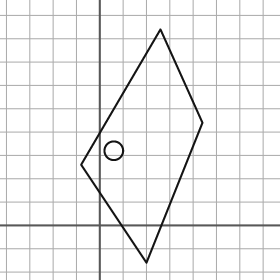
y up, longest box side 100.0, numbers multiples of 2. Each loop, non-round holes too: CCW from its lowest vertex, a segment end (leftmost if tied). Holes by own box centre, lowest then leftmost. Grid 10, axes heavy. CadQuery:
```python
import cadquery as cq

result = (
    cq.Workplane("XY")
    .moveTo(20.0, -16.0)
    .lineTo(44.0, 44.0)
    .lineTo(26.0, 84.0)
    .lineTo(-8.0, 26.0)
    .close()
    .moveTo(6.0, 32.0)
    .circle(4.0)
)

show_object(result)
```